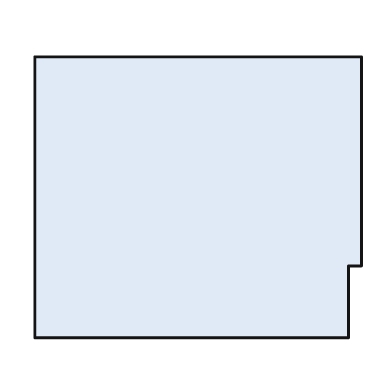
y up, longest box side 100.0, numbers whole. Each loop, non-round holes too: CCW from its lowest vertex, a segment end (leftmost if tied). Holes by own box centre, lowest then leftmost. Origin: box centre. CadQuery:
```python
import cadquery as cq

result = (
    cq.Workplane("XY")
    .moveTo(-50.0, -43.0)
    .lineTo(46.0, -43.0)
    .lineTo(46.0, -21.0)
    .lineTo(50.0, -21.0)
    .lineTo(50.0, 43.0)
    .lineTo(-50.0, 43.0)
    .close()
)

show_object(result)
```